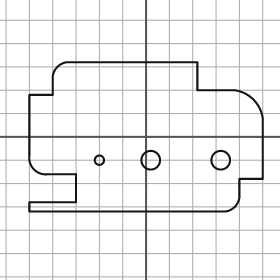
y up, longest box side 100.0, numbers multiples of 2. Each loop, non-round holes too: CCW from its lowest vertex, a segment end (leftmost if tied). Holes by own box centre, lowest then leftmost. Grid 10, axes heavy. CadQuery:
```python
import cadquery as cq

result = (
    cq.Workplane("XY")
    .moveTo(-50.0, -32.0)
    .lineTo(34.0, -32.0)
    .threePointArc((38.0, -30.0), (40.0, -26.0))
    .lineTo(40.0, -18.0)
    .lineTo(50.0, -18.0)
    .lineTo(50.0, 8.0)
    .threePointArc((46.0, 16.0), (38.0, 20.0))
    .lineTo(22.0, 20.0)
    .lineTo(22.0, 32.0)
    .lineTo(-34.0, 32.0)
    .threePointArc((-38.0, 30.0), (-40.0, 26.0))
    .lineTo(-40.0, 18.0)
    .lineTo(-50.0, 18.0)
    .lineTo(-50.0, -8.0)
    .threePointArc((-48.0, -14.0), (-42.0, -16.0))
    .lineTo(-30.0, -16.0)
    .lineTo(-30.0, -28.0)
    .lineTo(-50.0, -28.0)
    .close()
    .moveTo(-20.0, -10.0)
    .circle(2.0)
    .moveTo(2.0, -10.0)
    .circle(4.0)
    .moveTo(32.0, -10.0)
    .circle(4.0)
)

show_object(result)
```